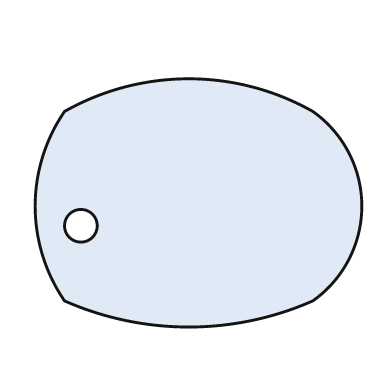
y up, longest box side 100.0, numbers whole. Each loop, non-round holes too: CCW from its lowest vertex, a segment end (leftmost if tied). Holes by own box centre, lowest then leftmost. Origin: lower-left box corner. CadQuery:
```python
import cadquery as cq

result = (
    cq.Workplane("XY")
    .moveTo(9.0, 8.0)
    .threePointArc((47.0, 0.0), (85.0, 8.0))
    .threePointArc((100.0, 37.0), (85.0, 66.0))
    .threePointArc((47.0, 76.0), (9.0, 66.0))
    .threePointArc((0.0, 37.0), (9.0, 8.0))
    .close()
    .moveTo(14.0, 31.0)
    .circle(5.0)
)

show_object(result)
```